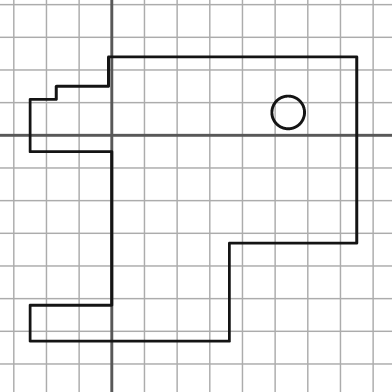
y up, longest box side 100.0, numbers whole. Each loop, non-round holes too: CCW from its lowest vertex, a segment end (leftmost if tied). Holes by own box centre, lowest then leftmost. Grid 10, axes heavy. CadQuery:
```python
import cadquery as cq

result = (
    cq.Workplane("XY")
    .moveTo(-25.0, -63.0)
    .lineTo(36.0, -63.0)
    .lineTo(36.0, -33.0)
    .lineTo(75.0, -33.0)
    .lineTo(75.0, 24.0)
    .lineTo(-1.0, 24.0)
    .lineTo(-1.0, 15.0)
    .lineTo(-17.0, 15.0)
    .lineTo(-17.0, 11.0)
    .lineTo(-25.0, 11.0)
    .lineTo(-25.0, -5.0)
    .lineTo(0.0, -5.0)
    .lineTo(0.0, -52.0)
    .lineTo(-25.0, -52.0)
    .close()
    .moveTo(54.0, 7.0)
    .circle(5.0)
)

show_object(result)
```